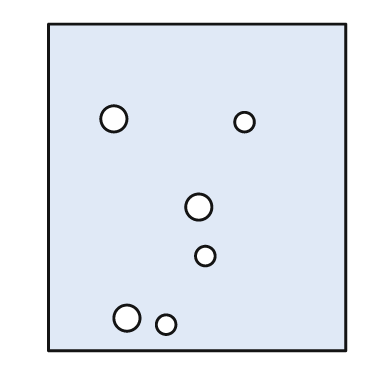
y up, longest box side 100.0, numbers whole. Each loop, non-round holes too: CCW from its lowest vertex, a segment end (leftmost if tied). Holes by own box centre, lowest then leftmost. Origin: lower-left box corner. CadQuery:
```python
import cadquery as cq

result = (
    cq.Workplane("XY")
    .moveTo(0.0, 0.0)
    .lineTo(91.0, 0.0)
    .lineTo(91.0, 100.0)
    .lineTo(0.0, 100.0)
    .close()
    .moveTo(36.0, 8.0)
    .circle(3.0)
    .moveTo(24.0, 10.0)
    .circle(4.0)
    .moveTo(48.0, 29.0)
    .circle(3.0)
    .moveTo(46.0, 44.0)
    .circle(4.0)
    .moveTo(60.0, 70.0)
    .circle(3.0)
    .moveTo(20.0, 71.0)
    .circle(4.0)
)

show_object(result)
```